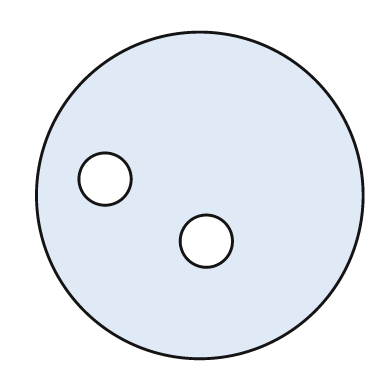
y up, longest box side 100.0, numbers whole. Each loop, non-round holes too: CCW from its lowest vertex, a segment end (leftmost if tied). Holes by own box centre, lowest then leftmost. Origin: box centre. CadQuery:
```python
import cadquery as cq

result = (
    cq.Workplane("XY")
    .moveTo(0.0, 0.0)
    .circle(50.0)
    .moveTo(2.0, -14.0)
    .circle(8.0)
    .moveTo(-29.0, 5.0)
    .circle(8.0)
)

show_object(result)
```